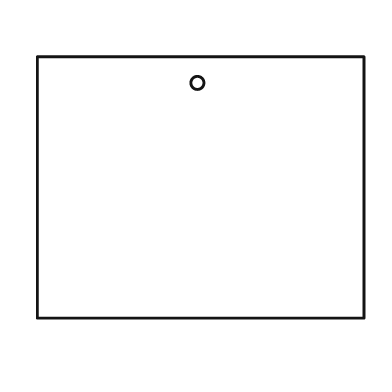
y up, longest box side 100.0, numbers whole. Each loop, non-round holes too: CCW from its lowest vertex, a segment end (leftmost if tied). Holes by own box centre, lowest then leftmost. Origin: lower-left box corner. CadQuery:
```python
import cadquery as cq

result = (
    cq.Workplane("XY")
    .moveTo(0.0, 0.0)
    .lineTo(100.0, 0.0)
    .lineTo(100.0, 80.0)
    .lineTo(0.0, 80.0)
    .close()
    .moveTo(49.0, 72.0)
    .circle(2.0)
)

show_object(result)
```